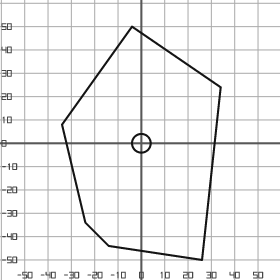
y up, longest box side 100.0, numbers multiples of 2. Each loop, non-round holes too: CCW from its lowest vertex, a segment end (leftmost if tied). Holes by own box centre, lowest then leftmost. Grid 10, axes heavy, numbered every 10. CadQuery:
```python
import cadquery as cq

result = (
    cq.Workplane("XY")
    .moveTo(26.0, -50.0)
    .lineTo(34.0, 24.0)
    .lineTo(-4.0, 50.0)
    .lineTo(-34.0, 8.0)
    .lineTo(-24.0, -34.0)
    .lineTo(-14.0, -44.0)
    .close()
    .moveTo(0.0, 0.0)
    .circle(4.0)
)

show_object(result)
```